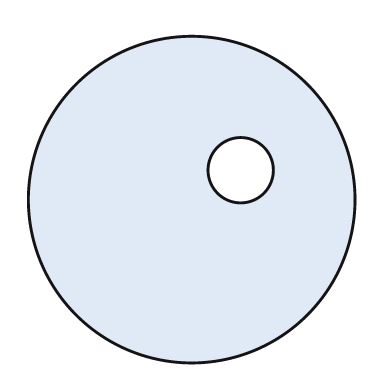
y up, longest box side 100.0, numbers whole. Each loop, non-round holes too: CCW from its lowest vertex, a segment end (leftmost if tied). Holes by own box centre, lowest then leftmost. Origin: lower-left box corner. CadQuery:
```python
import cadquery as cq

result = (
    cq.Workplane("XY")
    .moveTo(50.0, 50.0)
    .circle(50.0)
    .moveTo(65.0, 59.0)
    .circle(10.0)
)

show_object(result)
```